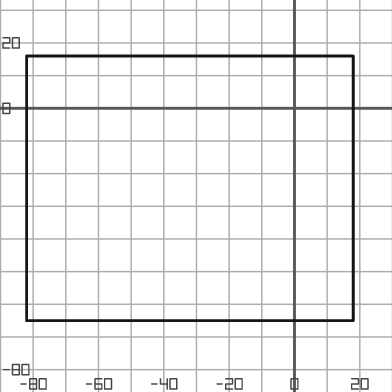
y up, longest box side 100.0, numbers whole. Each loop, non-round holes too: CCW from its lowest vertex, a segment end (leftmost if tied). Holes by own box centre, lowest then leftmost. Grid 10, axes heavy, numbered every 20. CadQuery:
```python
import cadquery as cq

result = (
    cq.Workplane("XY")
    .moveTo(-82.0, -65.0)
    .lineTo(18.0, -65.0)
    .lineTo(18.0, 16.0)
    .lineTo(-82.0, 16.0)
    .close()
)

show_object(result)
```